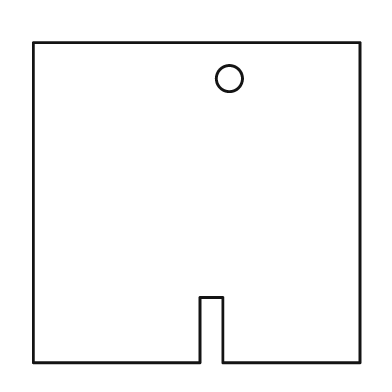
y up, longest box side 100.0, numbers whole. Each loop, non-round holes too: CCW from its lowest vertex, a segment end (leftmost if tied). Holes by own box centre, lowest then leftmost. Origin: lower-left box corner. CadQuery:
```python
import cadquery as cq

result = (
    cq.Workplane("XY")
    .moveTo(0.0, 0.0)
    .lineTo(51.0, 0.0)
    .lineTo(51.0, 20.0)
    .lineTo(58.0, 20.0)
    .lineTo(58.0, 0.0)
    .lineTo(100.0, 0.0)
    .lineTo(100.0, 98.0)
    .lineTo(0.0, 98.0)
    .close()
    .moveTo(60.0, 87.0)
    .circle(4.0)
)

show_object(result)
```